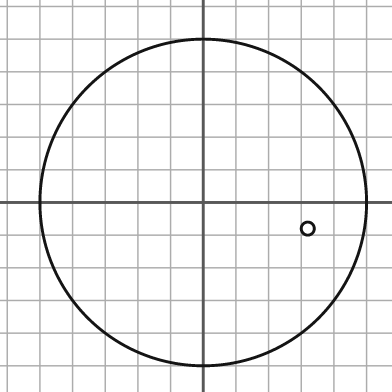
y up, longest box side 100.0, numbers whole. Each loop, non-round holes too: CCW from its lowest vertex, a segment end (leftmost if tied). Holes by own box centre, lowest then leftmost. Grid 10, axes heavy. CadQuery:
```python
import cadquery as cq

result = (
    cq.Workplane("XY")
    .moveTo(0.0, 0.0)
    .circle(50.0)
    .moveTo(32.0, -8.0)
    .circle(2.0)
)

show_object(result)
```